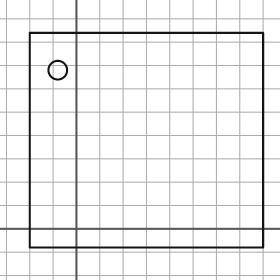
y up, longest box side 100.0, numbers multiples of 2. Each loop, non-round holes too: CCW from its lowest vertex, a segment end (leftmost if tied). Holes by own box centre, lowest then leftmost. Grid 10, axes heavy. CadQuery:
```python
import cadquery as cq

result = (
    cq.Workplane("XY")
    .moveTo(-20.0, -8.0)
    .lineTo(80.0, -8.0)
    .lineTo(80.0, 84.0)
    .lineTo(-20.0, 84.0)
    .close()
    .moveTo(-8.0, 68.0)
    .circle(4.0)
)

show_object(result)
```